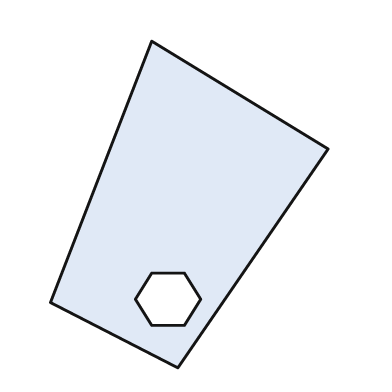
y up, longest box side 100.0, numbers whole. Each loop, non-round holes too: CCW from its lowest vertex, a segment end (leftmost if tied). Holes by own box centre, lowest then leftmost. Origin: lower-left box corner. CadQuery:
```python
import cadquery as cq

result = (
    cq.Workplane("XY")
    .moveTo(39.0, 0.0)
    .lineTo(85.0, 67.0)
    .lineTo(31.0, 100.0)
    .lineTo(0.0, 20.0)
    .close()
    .moveTo(31.0, 13.0)
    .lineTo(41.0, 13.0)
    .lineTo(46.0, 21.0)
    .lineTo(41.0, 29.0)
    .lineTo(31.0, 29.0)
    .lineTo(26.0, 21.0)
    .close()
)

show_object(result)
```